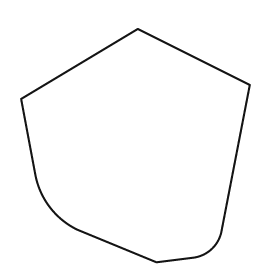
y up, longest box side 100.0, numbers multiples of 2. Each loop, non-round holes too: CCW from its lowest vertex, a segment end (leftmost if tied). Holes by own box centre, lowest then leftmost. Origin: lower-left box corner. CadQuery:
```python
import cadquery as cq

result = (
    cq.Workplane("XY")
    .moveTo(58.0, 0.0)
    .lineTo(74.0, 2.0)
    .threePointArc((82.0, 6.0), (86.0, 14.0))
    .lineTo(98.0, 76.0)
    .lineTo(50.0, 100.0)
    .lineTo(0.0, 70.0)
    .lineTo(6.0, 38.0)
    .threePointArc((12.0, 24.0), (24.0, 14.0))
    .close()
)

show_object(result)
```